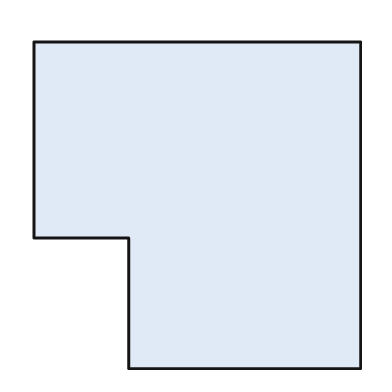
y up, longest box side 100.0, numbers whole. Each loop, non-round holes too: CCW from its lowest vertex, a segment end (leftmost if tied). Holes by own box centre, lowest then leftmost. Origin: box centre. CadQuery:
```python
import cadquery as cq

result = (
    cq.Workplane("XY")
    .moveTo(-21.0, -50.0)
    .lineTo(50.0, -50.0)
    .lineTo(50.0, 50.0)
    .lineTo(-50.0, 50.0)
    .lineTo(-50.0, -10.0)
    .lineTo(-21.0, -10.0)
    .close()
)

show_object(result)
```